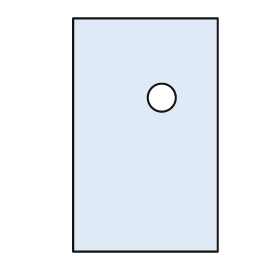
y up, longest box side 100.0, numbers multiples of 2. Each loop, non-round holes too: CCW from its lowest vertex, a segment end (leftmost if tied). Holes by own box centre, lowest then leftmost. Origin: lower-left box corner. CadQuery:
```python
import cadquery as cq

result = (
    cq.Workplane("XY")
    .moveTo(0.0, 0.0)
    .lineTo(62.0, 0.0)
    .lineTo(62.0, 100.0)
    .lineTo(0.0, 100.0)
    .close()
    .moveTo(38.0, 66.0)
    .circle(6.0)
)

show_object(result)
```